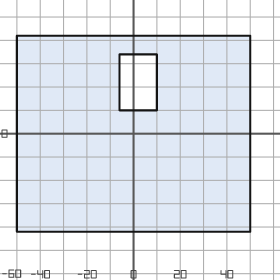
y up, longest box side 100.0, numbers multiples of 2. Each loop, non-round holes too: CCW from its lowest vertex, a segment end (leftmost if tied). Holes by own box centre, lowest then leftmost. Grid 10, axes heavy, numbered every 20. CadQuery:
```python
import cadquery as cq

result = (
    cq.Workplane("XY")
    .moveTo(-50.0, -42.0)
    .lineTo(50.0, -42.0)
    .lineTo(50.0, 42.0)
    .lineTo(-50.0, 42.0)
    .close()
    .moveTo(-6.0, 10.0)
    .lineTo(10.0, 10.0)
    .lineTo(10.0, 34.0)
    .lineTo(-6.0, 34.0)
    .close()
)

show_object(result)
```